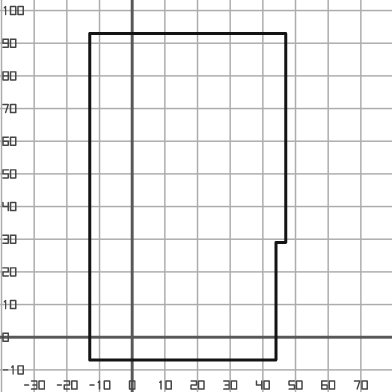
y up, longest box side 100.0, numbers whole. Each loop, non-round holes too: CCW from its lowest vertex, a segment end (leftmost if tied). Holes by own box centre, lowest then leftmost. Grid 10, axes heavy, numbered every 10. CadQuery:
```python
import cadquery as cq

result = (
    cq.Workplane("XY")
    .moveTo(-13.0, -7.0)
    .lineTo(44.0, -7.0)
    .lineTo(44.0, 29.0)
    .lineTo(47.0, 29.0)
    .lineTo(47.0, 93.0)
    .lineTo(-13.0, 93.0)
    .close()
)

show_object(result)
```